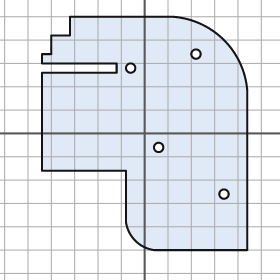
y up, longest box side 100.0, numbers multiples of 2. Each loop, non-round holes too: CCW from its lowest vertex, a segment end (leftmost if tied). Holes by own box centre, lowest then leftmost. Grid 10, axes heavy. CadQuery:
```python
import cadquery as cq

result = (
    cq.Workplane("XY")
    .moveTo(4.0, -50.0)
    .lineTo(44.0, -50.0)
    .lineTo(44.0, 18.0)
    .threePointArc((34.0, 40.0), (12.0, 50.0))
    .lineTo(-32.0, 50.0)
    .lineTo(-32.0, 42.0)
    .lineTo(-40.0, 42.0)
    .lineTo(-40.0, 34.0)
    .lineTo(-44.0, 34.0)
    .lineTo(-44.0, 30.0)
    .lineTo(-12.0, 30.0)
    .lineTo(-12.0, 26.0)
    .lineTo(-44.0, 26.0)
    .lineTo(-44.0, -16.0)
    .lineTo(-8.0, -16.0)
    .lineTo(-8.0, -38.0)
    .threePointArc((-4.0, -46.0), (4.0, -50.0))
    .close()
    .moveTo(34.0, -26.0)
    .circle(2.0)
    .moveTo(6.0, -6.0)
    .circle(2.0)
    .moveTo(-6.0, 28.0)
    .circle(2.0)
    .moveTo(22.0, 34.0)
    .circle(2.0)
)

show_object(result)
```